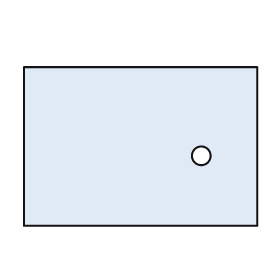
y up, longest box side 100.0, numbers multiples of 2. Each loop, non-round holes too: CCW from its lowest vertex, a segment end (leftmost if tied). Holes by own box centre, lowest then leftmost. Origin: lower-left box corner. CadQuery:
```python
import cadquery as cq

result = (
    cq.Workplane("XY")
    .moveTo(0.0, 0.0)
    .lineTo(100.0, 0.0)
    .lineTo(100.0, 68.0)
    .lineTo(0.0, 68.0)
    .close()
    .moveTo(76.0, 30.0)
    .circle(4.0)
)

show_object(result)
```